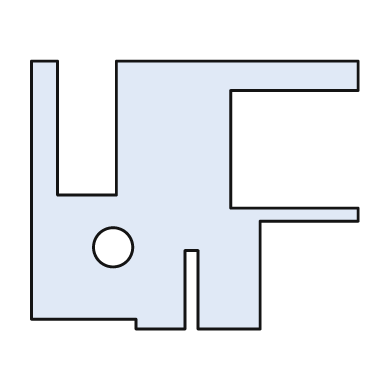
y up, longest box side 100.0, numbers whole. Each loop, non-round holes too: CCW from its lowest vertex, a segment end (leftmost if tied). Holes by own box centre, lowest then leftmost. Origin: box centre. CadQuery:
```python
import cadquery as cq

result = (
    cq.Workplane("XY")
    .moveTo(-18.0, -41.0)
    .lineTo(-3.0, -41.0)
    .lineTo(-3.0, -17.0)
    .lineTo(1.0, -17.0)
    .lineTo(1.0, -41.0)
    .lineTo(20.0, -41.0)
    .lineTo(20.0, -8.0)
    .lineTo(50.0, -8.0)
    .lineTo(50.0, -4.0)
    .lineTo(11.0, -4.0)
    .lineTo(11.0, 32.0)
    .lineTo(50.0, 32.0)
    .lineTo(50.0, 41.0)
    .lineTo(-24.0, 41.0)
    .lineTo(-24.0, 0.0)
    .lineTo(-42.0, 0.0)
    .lineTo(-42.0, 41.0)
    .lineTo(-50.0, 41.0)
    .lineTo(-50.0, -38.0)
    .lineTo(-18.0, -38.0)
    .close()
    .moveTo(-25.0, -16.0)
    .circle(6.0)
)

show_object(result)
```